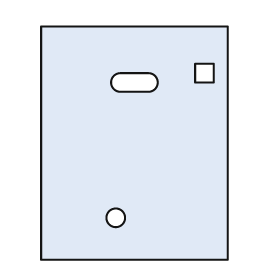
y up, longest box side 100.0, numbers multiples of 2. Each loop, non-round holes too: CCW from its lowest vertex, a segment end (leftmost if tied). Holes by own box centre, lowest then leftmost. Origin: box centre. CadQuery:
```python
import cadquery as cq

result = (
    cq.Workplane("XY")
    .moveTo(-40.0, -50.0)
    .lineTo(40.0, -50.0)
    .lineTo(40.0, 50.0)
    .lineTo(-40.0, 50.0)
    .close()
    .moveTo(-8.0, -32.0)
    .circle(4.0)
    .moveTo(-6.0, 22.0)
    .lineTo(6.0, 22.0)
    .threePointArc((10.0, 26.0), (6.0, 30.0))
    .lineTo(-6.0, 30.0)
    .threePointArc((-10.0, 26.0), (-6.0, 22.0))
    .close()
    .moveTo(26.0, 26.0)
    .lineTo(34.0, 26.0)
    .lineTo(34.0, 34.0)
    .lineTo(26.0, 34.0)
    .close()
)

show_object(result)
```